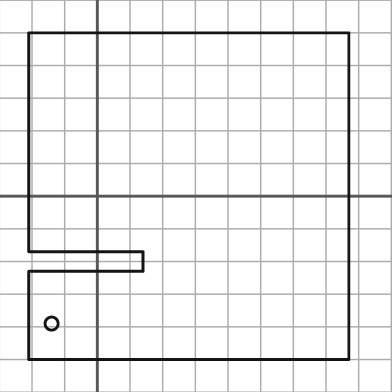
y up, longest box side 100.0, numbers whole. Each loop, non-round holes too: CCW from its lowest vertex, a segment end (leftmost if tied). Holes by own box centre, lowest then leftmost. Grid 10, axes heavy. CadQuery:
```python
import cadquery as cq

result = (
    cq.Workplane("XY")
    .moveTo(-21.0, -50.0)
    .lineTo(77.0, -50.0)
    .lineTo(77.0, 50.0)
    .lineTo(-21.0, 50.0)
    .lineTo(-21.0, -17.0)
    .lineTo(14.0, -17.0)
    .lineTo(14.0, -23.0)
    .lineTo(-21.0, -23.0)
    .close()
    .moveTo(-14.0, -39.0)
    .circle(2.0)
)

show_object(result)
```